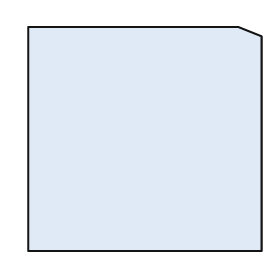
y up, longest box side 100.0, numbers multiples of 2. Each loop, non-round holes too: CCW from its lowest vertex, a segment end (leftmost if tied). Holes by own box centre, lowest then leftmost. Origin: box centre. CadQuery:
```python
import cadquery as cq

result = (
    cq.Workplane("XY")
    .moveTo(-50.0, -48.0)
    .lineTo(50.0, -48.0)
    .lineTo(50.0, 44.0)
    .lineTo(40.0, 48.0)
    .lineTo(-50.0, 48.0)
    .close()
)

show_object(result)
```